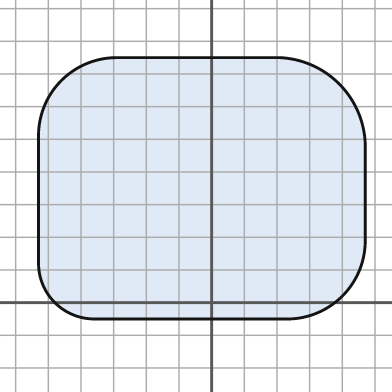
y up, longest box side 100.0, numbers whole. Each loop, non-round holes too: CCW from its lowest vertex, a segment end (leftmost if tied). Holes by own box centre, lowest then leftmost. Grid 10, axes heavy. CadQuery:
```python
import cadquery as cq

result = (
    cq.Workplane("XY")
    .moveTo(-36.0, -5.0)
    .lineTo(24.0, -5.0)
    .threePointArc((40.0, 2.0), (47.0, 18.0))
    .lineTo(47.0, 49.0)
    .threePointArc((39.0, 67.0), (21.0, 75.0))
    .lineTo(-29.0, 75.0)
    .threePointArc((-46.0, 68.0), (-53.0, 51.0))
    .lineTo(-53.0, 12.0)
    .threePointArc((-48.0, 0.0), (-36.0, -5.0))
    .close()
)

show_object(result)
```